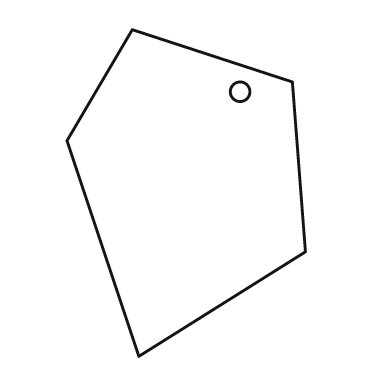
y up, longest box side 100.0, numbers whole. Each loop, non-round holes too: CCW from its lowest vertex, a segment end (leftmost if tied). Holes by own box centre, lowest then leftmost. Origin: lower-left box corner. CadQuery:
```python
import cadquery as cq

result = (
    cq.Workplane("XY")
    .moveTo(22.0, 0.0)
    .lineTo(73.0, 32.0)
    .lineTo(69.0, 84.0)
    .lineTo(20.0, 100.0)
    .lineTo(0.0, 66.0)
    .close()
    .moveTo(53.0, 81.0)
    .circle(3.0)
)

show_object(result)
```